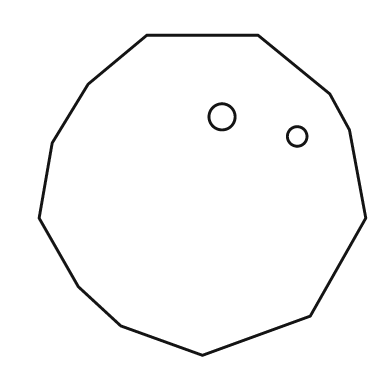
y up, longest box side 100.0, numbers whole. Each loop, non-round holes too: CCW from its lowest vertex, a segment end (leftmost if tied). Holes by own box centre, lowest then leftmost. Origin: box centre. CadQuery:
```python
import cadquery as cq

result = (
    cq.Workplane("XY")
    .moveTo(0.0, -49.0)
    .lineTo(33.0, -37.0)
    .lineTo(50.0, -7.0)
    .lineTo(45.0, 20.0)
    .lineTo(39.0, 31.0)
    .lineTo(17.0, 49.0)
    .lineTo(-17.0, 49.0)
    .lineTo(-35.0, 34.0)
    .lineTo(-46.0, 16.0)
    .lineTo(-50.0, -7.0)
    .lineTo(-38.0, -28.0)
    .lineTo(-25.0, -40.0)
    .close()
    .moveTo(29.0, 18.0)
    .circle(3.0)
    .moveTo(6.0, 24.0)
    .circle(4.0)
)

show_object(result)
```